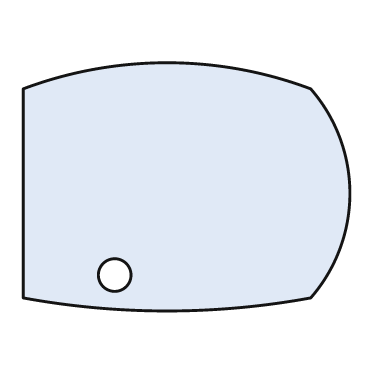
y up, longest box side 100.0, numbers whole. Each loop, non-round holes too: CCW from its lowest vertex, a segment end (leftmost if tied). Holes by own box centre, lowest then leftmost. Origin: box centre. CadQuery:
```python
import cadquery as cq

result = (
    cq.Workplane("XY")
    .moveTo(-50.0, -34.0)
    .threePointArc((-6.0, -38.0), (38.0, -34.0))
    .threePointArc((50.0, -2.0), (38.0, 30.0))
    .threePointArc((-6.0, 38.0), (-50.0, 30.0))
    .close()
    .moveTo(-22.0, -27.0)
    .circle(5.0)
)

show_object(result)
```